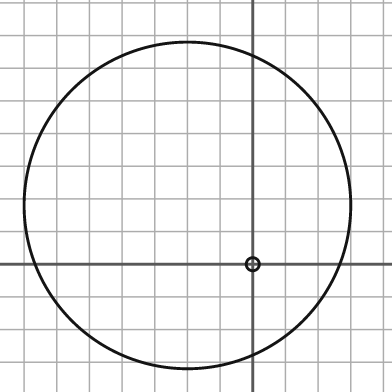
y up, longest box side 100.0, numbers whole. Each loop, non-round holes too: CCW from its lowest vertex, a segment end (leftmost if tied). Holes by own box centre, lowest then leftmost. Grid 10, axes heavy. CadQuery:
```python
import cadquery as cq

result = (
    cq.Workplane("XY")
    .moveTo(-20.0, 18.0)
    .circle(50.0)
    .moveTo(0.0, 0.0)
    .circle(2.0)
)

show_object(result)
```